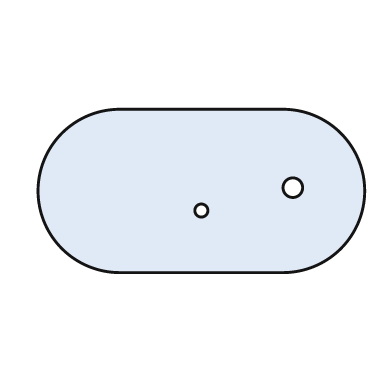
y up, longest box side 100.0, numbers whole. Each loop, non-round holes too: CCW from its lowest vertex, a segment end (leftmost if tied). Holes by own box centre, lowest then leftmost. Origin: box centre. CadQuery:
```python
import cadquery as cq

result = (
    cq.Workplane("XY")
    .moveTo(-25.0, -25.0)
    .lineTo(25.0, -25.0)
    .threePointArc((50.0, 0.0), (25.0, 25.0))
    .lineTo(-25.0, 25.0)
    .threePointArc((-50.0, 0.0), (-25.0, -25.0))
    .close()
    .moveTo(0.0, -6.0)
    .circle(2.0)
    .moveTo(28.0, 1.0)
    .circle(3.0)
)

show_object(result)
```